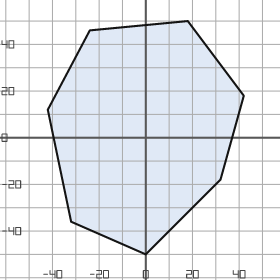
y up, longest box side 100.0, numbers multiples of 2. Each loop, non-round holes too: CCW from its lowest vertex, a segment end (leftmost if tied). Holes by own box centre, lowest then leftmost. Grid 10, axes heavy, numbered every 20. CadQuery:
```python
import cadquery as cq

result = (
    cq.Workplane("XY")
    .moveTo(0.0, -50.0)
    .lineTo(32.0, -18.0)
    .lineTo(42.0, 18.0)
    .lineTo(18.0, 50.0)
    .lineTo(-24.0, 46.0)
    .lineTo(-42.0, 12.0)
    .lineTo(-32.0, -36.0)
    .close()
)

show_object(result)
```